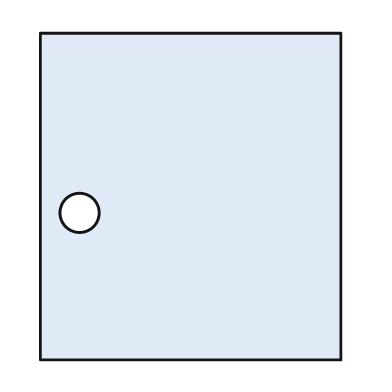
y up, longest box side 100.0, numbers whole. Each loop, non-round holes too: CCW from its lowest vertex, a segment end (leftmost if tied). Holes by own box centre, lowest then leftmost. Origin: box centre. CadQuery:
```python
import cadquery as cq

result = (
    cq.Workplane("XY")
    .moveTo(-46.0, -50.0)
    .lineTo(46.0, -50.0)
    .lineTo(46.0, 50.0)
    .lineTo(-46.0, 50.0)
    .close()
    .moveTo(-34.0, -5.0)
    .circle(6.0)
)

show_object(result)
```